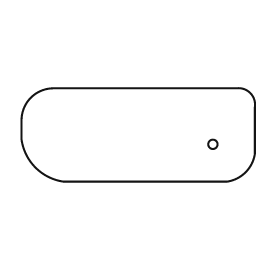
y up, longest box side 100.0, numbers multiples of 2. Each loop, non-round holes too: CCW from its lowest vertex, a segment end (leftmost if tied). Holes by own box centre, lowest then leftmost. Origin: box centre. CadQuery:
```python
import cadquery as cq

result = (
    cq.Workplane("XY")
    .moveTo(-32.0, -20.0)
    .lineTo(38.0, -20.0)
    .threePointArc((46.0, -16.0), (50.0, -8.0))
    .lineTo(50.0, 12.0)
    .threePointArc((48.0, 18.0), (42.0, 20.0))
    .lineTo(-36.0, 20.0)
    .threePointArc((-46.0, 16.0), (-50.0, 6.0))
    .lineTo(-50.0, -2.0)
    .threePointArc((-44.0, -14.0), (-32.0, -20.0))
    .close()
    .moveTo(32.0, -4.0)
    .circle(2.0)
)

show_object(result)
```